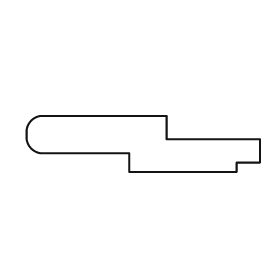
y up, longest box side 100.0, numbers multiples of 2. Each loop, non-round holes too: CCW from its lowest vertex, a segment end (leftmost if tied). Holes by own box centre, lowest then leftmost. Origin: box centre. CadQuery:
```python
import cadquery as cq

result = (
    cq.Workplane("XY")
    .moveTo(-6.0, -12.0)
    .lineTo(40.0, -12.0)
    .lineTo(40.0, -8.0)
    .lineTo(50.0, -8.0)
    .lineTo(50.0, 2.0)
    .lineTo(10.0, 2.0)
    .lineTo(10.0, 12.0)
    .lineTo(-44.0, 12.0)
    .threePointArc((-48.0, 10.0), (-50.0, 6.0))
    .lineTo(-50.0, 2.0)
    .threePointArc((-48.0, -2.0), (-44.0, -4.0))
    .lineTo(-6.0, -4.0)
    .close()
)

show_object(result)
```